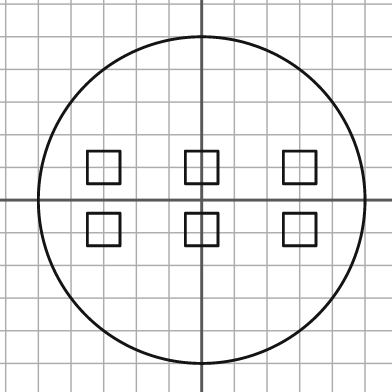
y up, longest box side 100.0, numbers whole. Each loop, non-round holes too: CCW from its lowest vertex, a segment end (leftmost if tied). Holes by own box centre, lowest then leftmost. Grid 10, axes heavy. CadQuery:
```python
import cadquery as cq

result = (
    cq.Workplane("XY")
    .moveTo(0.0, 0.0)
    .circle(50.0)
    .moveTo(-35.0, -14.0)
    .lineTo(-25.0, -14.0)
    .lineTo(-25.0, -4.0)
    .lineTo(-35.0, -4.0)
    .close()
    .moveTo(-5.0, -14.0)
    .lineTo(5.0, -14.0)
    .lineTo(5.0, -4.0)
    .lineTo(-5.0, -4.0)
    .close()
    .moveTo(25.0, -14.0)
    .lineTo(35.0, -14.0)
    .lineTo(35.0, -4.0)
    .lineTo(25.0, -4.0)
    .close()
    .moveTo(-35.0, 5.0)
    .lineTo(-25.0, 5.0)
    .lineTo(-25.0, 15.0)
    .lineTo(-35.0, 15.0)
    .close()
    .moveTo(-5.0, 5.0)
    .lineTo(5.0, 5.0)
    .lineTo(5.0, 15.0)
    .lineTo(-5.0, 15.0)
    .close()
    .moveTo(25.0, 5.0)
    .lineTo(35.0, 5.0)
    .lineTo(35.0, 15.0)
    .lineTo(25.0, 15.0)
    .close()
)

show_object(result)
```